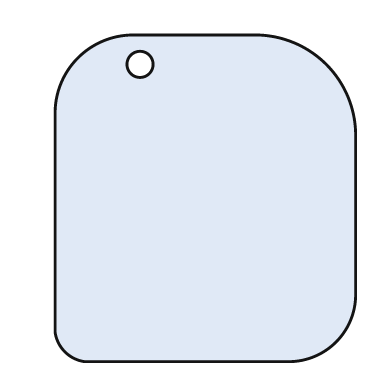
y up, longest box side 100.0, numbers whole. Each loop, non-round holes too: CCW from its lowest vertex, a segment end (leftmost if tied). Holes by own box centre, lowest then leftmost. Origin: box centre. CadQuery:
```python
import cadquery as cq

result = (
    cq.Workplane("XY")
    .moveTo(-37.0, -50.0)
    .lineTo(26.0, -50.0)
    .threePointArc((40.0, -44.0), (46.0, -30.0))
    .lineTo(46.0, 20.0)
    .threePointArc((37.0, 41.0), (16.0, 50.0))
    .lineTo(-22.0, 50.0)
    .threePointArc((-39.0, 43.0), (-46.0, 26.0))
    .lineTo(-46.0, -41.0)
    .threePointArc((-43.0, -47.0), (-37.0, -50.0))
    .close()
    .moveTo(-20.0, 41.0)
    .circle(4.0)
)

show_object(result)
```